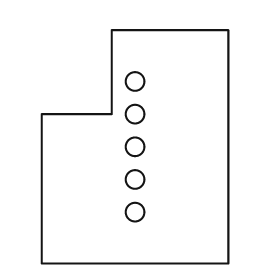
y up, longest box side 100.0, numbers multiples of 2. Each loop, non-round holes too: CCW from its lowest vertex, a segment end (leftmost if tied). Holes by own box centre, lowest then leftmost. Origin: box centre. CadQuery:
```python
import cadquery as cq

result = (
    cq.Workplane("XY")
    .moveTo(-40.0, -50.0)
    .lineTo(40.0, -50.0)
    .lineTo(40.0, 50.0)
    .lineTo(-10.0, 50.0)
    .lineTo(-10.0, 14.0)
    .lineTo(-40.0, 14.0)
    .close()
    .moveTo(0.0, -28.0)
    .circle(4.0)
    .moveTo(0.0, -14.0)
    .circle(4.0)
    .moveTo(0.0, 0.0)
    .circle(4.0)
    .moveTo(0.0, 14.0)
    .circle(4.0)
    .moveTo(0.0, 28.0)
    .circle(4.0)
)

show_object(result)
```